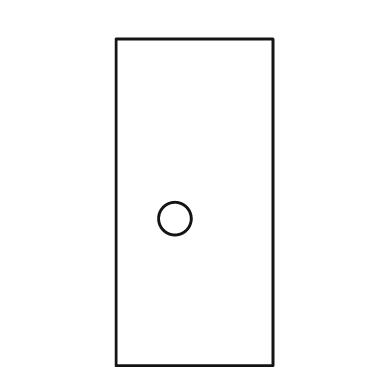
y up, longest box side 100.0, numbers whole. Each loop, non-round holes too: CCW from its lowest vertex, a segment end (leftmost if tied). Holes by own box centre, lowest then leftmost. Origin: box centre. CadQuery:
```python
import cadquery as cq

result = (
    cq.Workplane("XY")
    .moveTo(-24.0, -50.0)
    .lineTo(24.0, -50.0)
    .lineTo(24.0, 50.0)
    .lineTo(-24.0, 50.0)
    .close()
    .moveTo(-6.0, -5.0)
    .circle(5.0)
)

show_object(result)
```